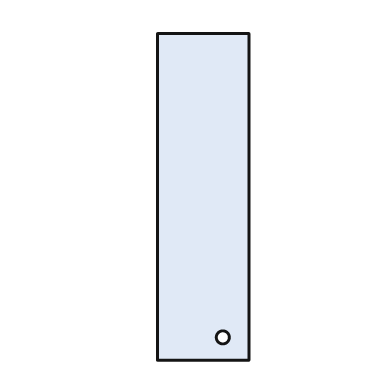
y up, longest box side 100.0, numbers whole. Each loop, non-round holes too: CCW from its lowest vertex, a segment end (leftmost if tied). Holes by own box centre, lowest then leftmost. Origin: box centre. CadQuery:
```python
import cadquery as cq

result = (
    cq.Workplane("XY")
    .moveTo(-14.0, -50.0)
    .lineTo(14.0, -50.0)
    .lineTo(14.0, 50.0)
    .lineTo(-14.0, 50.0)
    .close()
    .moveTo(6.0, -43.0)
    .circle(2.0)
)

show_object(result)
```